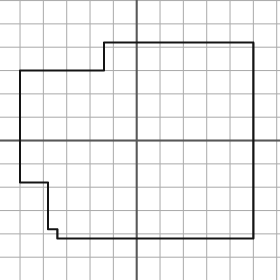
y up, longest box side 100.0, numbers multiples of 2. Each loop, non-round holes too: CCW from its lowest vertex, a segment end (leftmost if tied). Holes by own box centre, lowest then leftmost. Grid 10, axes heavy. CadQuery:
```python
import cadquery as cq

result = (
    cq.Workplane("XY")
    .moveTo(-34.0, -42.0)
    .lineTo(50.0, -42.0)
    .lineTo(50.0, 42.0)
    .lineTo(-14.0, 42.0)
    .lineTo(-14.0, 30.0)
    .lineTo(-50.0, 30.0)
    .lineTo(-50.0, -18.0)
    .lineTo(-38.0, -18.0)
    .lineTo(-38.0, -38.0)
    .lineTo(-34.0, -38.0)
    .close()
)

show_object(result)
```